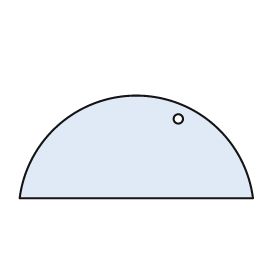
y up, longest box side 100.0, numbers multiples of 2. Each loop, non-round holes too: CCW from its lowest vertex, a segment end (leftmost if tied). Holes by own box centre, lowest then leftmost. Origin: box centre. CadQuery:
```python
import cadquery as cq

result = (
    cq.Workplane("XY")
    .moveTo(-50.0, -22.0)
    .lineTo(50.0, -22.0)
    .threePointArc((0.0, 22.0), (-50.0, -22.0))
    .close()
    .moveTo(18.0, 12.0)
    .circle(2.0)
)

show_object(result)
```